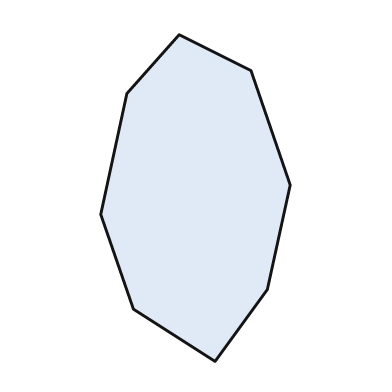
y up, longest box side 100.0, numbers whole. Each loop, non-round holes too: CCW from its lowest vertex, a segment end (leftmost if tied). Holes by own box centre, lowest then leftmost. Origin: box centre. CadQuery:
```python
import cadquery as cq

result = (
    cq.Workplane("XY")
    .moveTo(6.0, -50.0)
    .lineTo(22.0, -28.0)
    .lineTo(29.0, 4.0)
    .lineTo(17.0, 39.0)
    .lineTo(-5.0, 50.0)
    .lineTo(-21.0, 32.0)
    .lineTo(-29.0, -5.0)
    .lineTo(-19.0, -34.0)
    .close()
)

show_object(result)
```